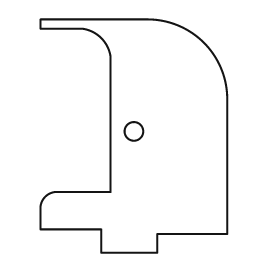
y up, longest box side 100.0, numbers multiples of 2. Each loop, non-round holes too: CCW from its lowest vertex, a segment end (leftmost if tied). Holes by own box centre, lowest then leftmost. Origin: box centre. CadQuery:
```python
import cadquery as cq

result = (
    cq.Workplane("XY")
    .moveTo(-14.0, -50.0)
    .lineTo(10.0, -50.0)
    .lineTo(10.0, -42.0)
    .lineTo(40.0, -42.0)
    .lineTo(40.0, 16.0)
    .threePointArc((30.0, 40.0), (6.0, 50.0))
    .lineTo(-40.0, 50.0)
    .lineTo(-40.0, 46.0)
    .lineTo(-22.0, 46.0)
    .threePointArc((-14.0, 42.0), (-10.0, 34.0))
    .lineTo(-10.0, -24.0)
    .lineTo(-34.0, -24.0)
    .threePointArc((-38.0, -26.0), (-40.0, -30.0))
    .lineTo(-40.0, -40.0)
    .lineTo(-14.0, -40.0)
    .close()
    .moveTo(0.0, 2.0)
    .circle(4.0)
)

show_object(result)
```